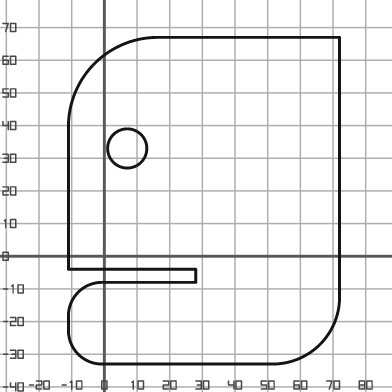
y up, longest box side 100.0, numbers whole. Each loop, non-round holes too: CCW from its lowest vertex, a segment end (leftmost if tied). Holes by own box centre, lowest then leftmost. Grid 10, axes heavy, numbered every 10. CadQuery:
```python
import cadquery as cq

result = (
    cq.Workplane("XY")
    .moveTo(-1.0, -33.0)
    .lineTo(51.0, -33.0)
    .threePointArc((66.0, -27.0), (72.0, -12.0))
    .lineTo(72.0, 67.0)
    .lineTo(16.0, 67.0)
    .threePointArc((-3.0, 59.0), (-11.0, 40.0))
    .lineTo(-11.0, -4.0)
    .lineTo(28.0, -4.0)
    .lineTo(28.0, -8.0)
    .lineTo(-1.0, -8.0)
    .threePointArc((-8.0, -11.0), (-11.0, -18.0))
    .lineTo(-11.0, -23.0)
    .threePointArc((-8.0, -30.0), (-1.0, -33.0))
    .close()
    .moveTo(7.0, 33.0)
    .circle(6.0)
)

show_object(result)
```